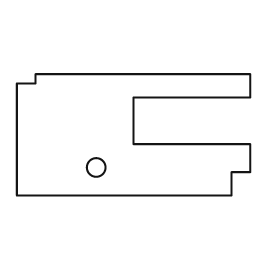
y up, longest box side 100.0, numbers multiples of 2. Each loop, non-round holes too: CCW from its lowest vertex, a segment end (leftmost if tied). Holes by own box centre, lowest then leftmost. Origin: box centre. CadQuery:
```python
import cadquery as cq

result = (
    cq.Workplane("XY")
    .moveTo(-50.0, -26.0)
    .lineTo(42.0, -26.0)
    .lineTo(42.0, -16.0)
    .lineTo(50.0, -16.0)
    .lineTo(50.0, -4.0)
    .lineTo(0.0, -4.0)
    .lineTo(0.0, 16.0)
    .lineTo(50.0, 16.0)
    .lineTo(50.0, 26.0)
    .lineTo(-42.0, 26.0)
    .lineTo(-42.0, 22.0)
    .lineTo(-50.0, 22.0)
    .close()
    .moveTo(-16.0, -14.0)
    .circle(4.0)
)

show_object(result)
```